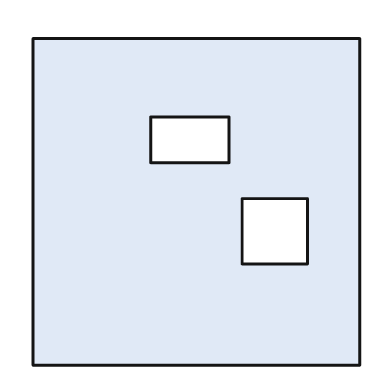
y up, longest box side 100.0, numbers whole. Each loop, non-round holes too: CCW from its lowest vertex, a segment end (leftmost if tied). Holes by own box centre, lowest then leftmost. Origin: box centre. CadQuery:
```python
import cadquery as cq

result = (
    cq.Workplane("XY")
    .moveTo(-50.0, -50.0)
    .lineTo(50.0, -50.0)
    .lineTo(50.0, 50.0)
    .lineTo(-50.0, 50.0)
    .close()
    .moveTo(14.0, -19.0)
    .lineTo(34.0, -19.0)
    .lineTo(34.0, 1.0)
    .lineTo(14.0, 1.0)
    .close()
    .moveTo(-14.0, 12.0)
    .lineTo(10.0, 12.0)
    .lineTo(10.0, 26.0)
    .lineTo(-14.0, 26.0)
    .close()
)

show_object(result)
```